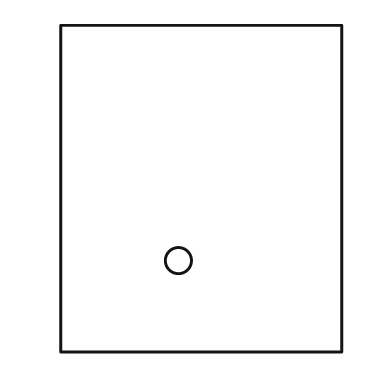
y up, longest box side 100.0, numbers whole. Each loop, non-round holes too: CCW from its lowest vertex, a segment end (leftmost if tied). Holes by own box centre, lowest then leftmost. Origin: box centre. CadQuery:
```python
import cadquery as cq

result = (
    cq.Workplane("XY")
    .moveTo(-43.0, -50.0)
    .lineTo(43.0, -50.0)
    .lineTo(43.0, 50.0)
    .lineTo(-43.0, 50.0)
    .close()
    .moveTo(-7.0, -22.0)
    .circle(4.0)
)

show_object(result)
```